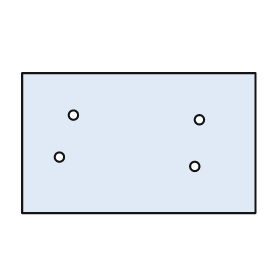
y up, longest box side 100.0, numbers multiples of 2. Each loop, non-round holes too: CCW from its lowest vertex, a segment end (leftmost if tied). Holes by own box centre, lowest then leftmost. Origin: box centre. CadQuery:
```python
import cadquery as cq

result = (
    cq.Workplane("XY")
    .moveTo(-50.0, -30.0)
    .lineTo(50.0, -30.0)
    .lineTo(50.0, 30.0)
    .lineTo(-50.0, 30.0)
    .close()
    .moveTo(24.0, -10.0)
    .circle(2.0)
    .moveTo(-34.0, -6.0)
    .circle(2.0)
    .moveTo(26.0, 10.0)
    .circle(2.0)
    .moveTo(-28.0, 12.0)
    .circle(2.0)
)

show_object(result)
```